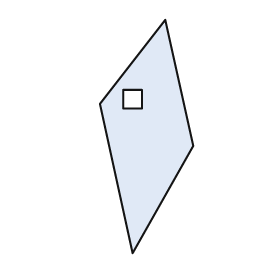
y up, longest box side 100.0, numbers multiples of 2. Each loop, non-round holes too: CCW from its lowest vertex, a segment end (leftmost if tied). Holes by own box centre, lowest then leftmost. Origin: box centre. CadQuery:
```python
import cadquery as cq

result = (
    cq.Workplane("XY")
    .moveTo(-6.0, -50.0)
    .lineTo(20.0, -4.0)
    .lineTo(8.0, 50.0)
    .lineTo(-20.0, 14.0)
    .close()
    .moveTo(-10.0, 12.0)
    .lineTo(-2.0, 12.0)
    .lineTo(-2.0, 20.0)
    .lineTo(-10.0, 20.0)
    .close()
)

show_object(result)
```